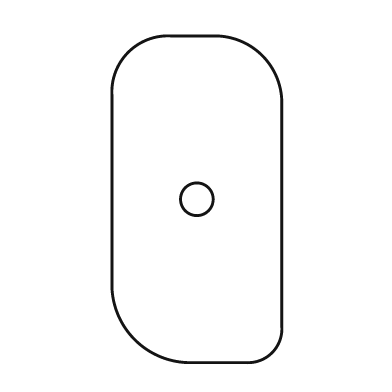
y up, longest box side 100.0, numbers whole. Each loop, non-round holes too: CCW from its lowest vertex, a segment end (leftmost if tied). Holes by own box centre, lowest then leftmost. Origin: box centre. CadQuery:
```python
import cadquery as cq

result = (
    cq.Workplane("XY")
    .moveTo(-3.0, -50.0)
    .lineTo(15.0, -50.0)
    .threePointArc((23.0, -47.0), (26.0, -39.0))
    .lineTo(26.0, 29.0)
    .threePointArc((20.0, 44.0), (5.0, 50.0))
    .lineTo(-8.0, 50.0)
    .threePointArc((-21.0, 45.0), (-26.0, 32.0))
    .lineTo(-26.0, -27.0)
    .threePointArc((-19.0, -43.0), (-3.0, -50.0))
    .close()
    .moveTo(0.0, 0.0)
    .circle(5.0)
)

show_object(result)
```